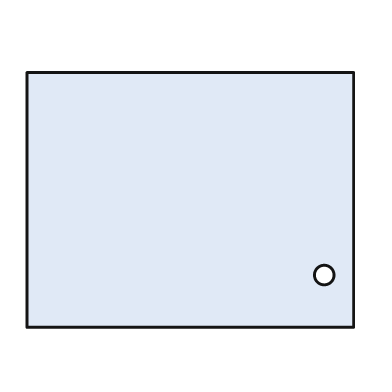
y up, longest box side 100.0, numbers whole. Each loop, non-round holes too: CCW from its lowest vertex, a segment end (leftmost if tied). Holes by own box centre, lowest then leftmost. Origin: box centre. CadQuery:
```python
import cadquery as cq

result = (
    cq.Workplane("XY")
    .moveTo(-50.0, -39.0)
    .lineTo(50.0, -39.0)
    .lineTo(50.0, 39.0)
    .lineTo(-50.0, 39.0)
    .close()
    .moveTo(41.0, -23.0)
    .circle(3.0)
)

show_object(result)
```